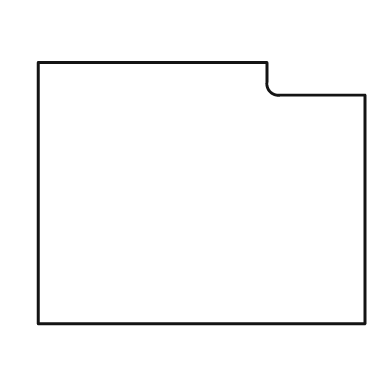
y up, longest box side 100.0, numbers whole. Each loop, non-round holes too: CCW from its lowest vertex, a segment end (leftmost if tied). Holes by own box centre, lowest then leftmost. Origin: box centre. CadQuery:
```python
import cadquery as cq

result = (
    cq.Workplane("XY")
    .moveTo(-50.0, -40.0)
    .lineTo(50.0, -40.0)
    .lineTo(50.0, 30.0)
    .lineTo(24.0, 30.0)
    .threePointArc((21.0, 31.0), (20.0, 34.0))
    .lineTo(20.0, 40.0)
    .lineTo(-50.0, 40.0)
    .close()
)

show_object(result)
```